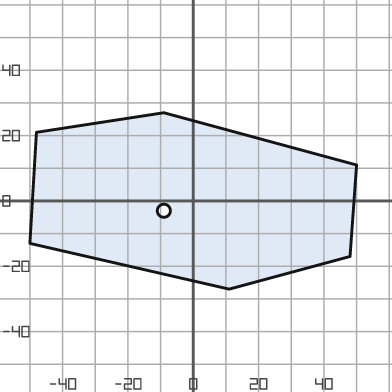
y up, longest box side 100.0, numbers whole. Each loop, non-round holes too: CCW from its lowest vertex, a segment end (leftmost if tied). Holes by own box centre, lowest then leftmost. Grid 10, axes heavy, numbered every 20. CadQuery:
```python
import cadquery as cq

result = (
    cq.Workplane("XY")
    .moveTo(11.0, -27.0)
    .lineTo(48.0, -17.0)
    .lineTo(50.0, 11.0)
    .lineTo(-9.0, 27.0)
    .lineTo(-48.0, 21.0)
    .lineTo(-50.0, -13.0)
    .close()
    .moveTo(-9.0, -3.0)
    .circle(2.0)
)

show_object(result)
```